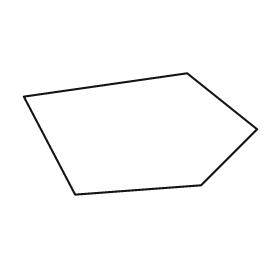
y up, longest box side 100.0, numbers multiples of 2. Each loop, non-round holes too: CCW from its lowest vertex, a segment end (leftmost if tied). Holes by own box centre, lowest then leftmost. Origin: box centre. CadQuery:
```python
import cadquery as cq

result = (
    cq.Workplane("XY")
    .moveTo(-28.0, -26.0)
    .lineTo(26.0, -22.0)
    .lineTo(50.0, 2.0)
    .lineTo(20.0, 26.0)
    .lineTo(-50.0, 16.0)
    .close()
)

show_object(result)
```